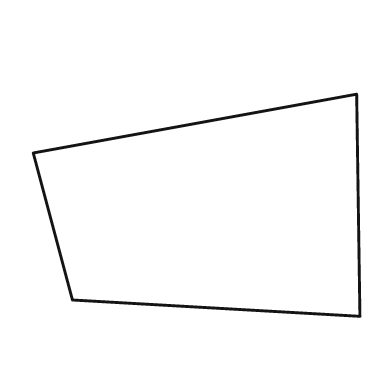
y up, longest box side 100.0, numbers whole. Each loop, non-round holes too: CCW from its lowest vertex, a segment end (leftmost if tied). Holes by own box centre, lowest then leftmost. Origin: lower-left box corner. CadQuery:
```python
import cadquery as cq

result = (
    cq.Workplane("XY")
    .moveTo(100.0, 0.0)
    .lineTo(99.0, 68.0)
    .lineTo(0.0, 50.0)
    .lineTo(12.0, 5.0)
    .close()
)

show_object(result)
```